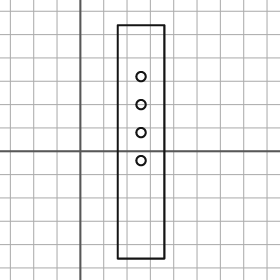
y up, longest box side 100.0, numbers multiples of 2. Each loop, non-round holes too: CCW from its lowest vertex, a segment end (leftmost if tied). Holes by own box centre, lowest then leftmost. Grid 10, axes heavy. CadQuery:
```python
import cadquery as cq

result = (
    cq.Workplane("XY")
    .moveTo(16.0, -46.0)
    .lineTo(36.0, -46.0)
    .lineTo(36.0, 54.0)
    .lineTo(16.0, 54.0)
    .close()
    .moveTo(26.0, -4.0)
    .circle(2.0)
    .moveTo(26.0, 8.0)
    .circle(2.0)
    .moveTo(26.0, 20.0)
    .circle(2.0)
    .moveTo(26.0, 32.0)
    .circle(2.0)
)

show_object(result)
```